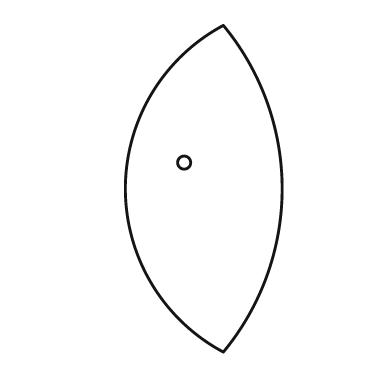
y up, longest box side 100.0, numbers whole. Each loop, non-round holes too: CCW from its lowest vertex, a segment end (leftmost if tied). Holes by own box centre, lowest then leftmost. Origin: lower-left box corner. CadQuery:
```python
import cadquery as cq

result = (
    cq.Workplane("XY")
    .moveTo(30.0, 0.0)
    .threePointArc((48.0, 50.0), (30.0, 100.0))
    .threePointArc((0.0, 50.0), (30.0, 0.0))
    .close()
    .moveTo(18.0, 58.0)
    .circle(2.0)
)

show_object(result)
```